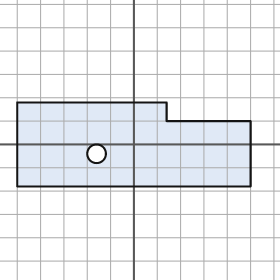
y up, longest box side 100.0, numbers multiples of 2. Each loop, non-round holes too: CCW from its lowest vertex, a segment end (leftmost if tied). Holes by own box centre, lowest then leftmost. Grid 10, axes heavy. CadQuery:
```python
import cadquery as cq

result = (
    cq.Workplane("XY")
    .moveTo(-50.0, -18.0)
    .lineTo(50.0, -18.0)
    .lineTo(50.0, 10.0)
    .lineTo(14.0, 10.0)
    .lineTo(14.0, 18.0)
    .lineTo(-50.0, 18.0)
    .close()
    .moveTo(-16.0, -4.0)
    .circle(4.0)
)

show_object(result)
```